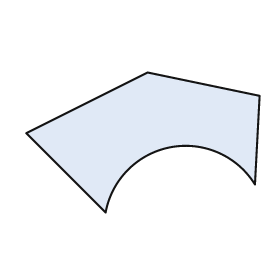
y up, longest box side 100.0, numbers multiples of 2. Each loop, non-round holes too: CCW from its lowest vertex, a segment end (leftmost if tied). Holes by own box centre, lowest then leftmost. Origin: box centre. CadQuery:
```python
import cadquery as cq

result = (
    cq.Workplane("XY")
    .moveTo(-16.0, -30.0)
    .threePointArc((12.0, -2.0), (48.0, -18.0))
    .lineTo(50.0, 20.0)
    .lineTo(2.0, 30.0)
    .lineTo(-50.0, 4.0)
    .close()
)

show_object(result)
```